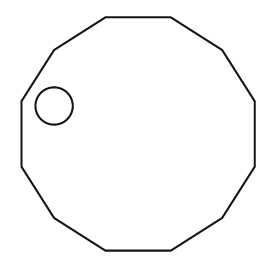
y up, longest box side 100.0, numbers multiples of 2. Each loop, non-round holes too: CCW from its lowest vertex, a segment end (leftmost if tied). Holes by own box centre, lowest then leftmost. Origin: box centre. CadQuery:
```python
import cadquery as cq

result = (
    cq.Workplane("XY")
    .moveTo(-14.0, -50.0)
    .lineTo(14.0, -50.0)
    .lineTo(36.0, -36.0)
    .lineTo(50.0, -14.0)
    .lineTo(50.0, 14.0)
    .lineTo(36.0, 36.0)
    .lineTo(14.0, 50.0)
    .lineTo(-14.0, 50.0)
    .lineTo(-36.0, 36.0)
    .lineTo(-50.0, 14.0)
    .lineTo(-50.0, -14.0)
    .lineTo(-36.0, -36.0)
    .close()
    .moveTo(-36.0, 12.0)
    .circle(8.0)
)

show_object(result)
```